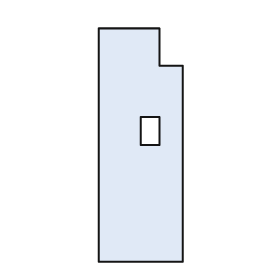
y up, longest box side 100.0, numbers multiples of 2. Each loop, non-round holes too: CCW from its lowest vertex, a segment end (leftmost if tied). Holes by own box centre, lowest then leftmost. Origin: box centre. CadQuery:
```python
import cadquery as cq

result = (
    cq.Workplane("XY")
    .moveTo(-18.0, -50.0)
    .lineTo(18.0, -50.0)
    .lineTo(18.0, 34.0)
    .lineTo(8.0, 34.0)
    .lineTo(8.0, 50.0)
    .lineTo(-18.0, 50.0)
    .close()
    .moveTo(0.0, 0.0)
    .lineTo(8.0, 0.0)
    .lineTo(8.0, 12.0)
    .lineTo(0.0, 12.0)
    .close()
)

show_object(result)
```